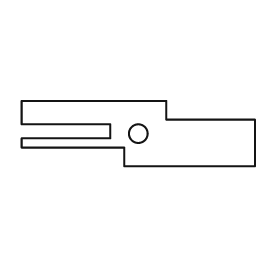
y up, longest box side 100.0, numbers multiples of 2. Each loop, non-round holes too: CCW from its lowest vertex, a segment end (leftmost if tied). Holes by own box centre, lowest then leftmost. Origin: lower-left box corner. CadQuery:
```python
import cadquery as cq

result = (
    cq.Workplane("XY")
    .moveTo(44.0, 0.0)
    .lineTo(100.0, 0.0)
    .lineTo(100.0, 20.0)
    .lineTo(62.0, 20.0)
    .lineTo(62.0, 28.0)
    .lineTo(0.0, 28.0)
    .lineTo(0.0, 18.0)
    .lineTo(38.0, 18.0)
    .lineTo(38.0, 12.0)
    .lineTo(0.0, 12.0)
    .lineTo(0.0, 8.0)
    .lineTo(44.0, 8.0)
    .close()
    .moveTo(50.0, 14.0)
    .circle(4.0)
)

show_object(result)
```